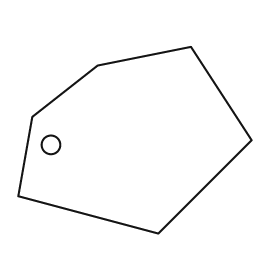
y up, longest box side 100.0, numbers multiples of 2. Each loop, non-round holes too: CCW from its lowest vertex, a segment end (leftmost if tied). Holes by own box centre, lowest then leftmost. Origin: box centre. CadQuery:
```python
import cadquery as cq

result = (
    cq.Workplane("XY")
    .moveTo(10.0, -40.0)
    .lineTo(50.0, 0.0)
    .lineTo(24.0, 40.0)
    .lineTo(-16.0, 32.0)
    .lineTo(-44.0, 10.0)
    .lineTo(-50.0, -24.0)
    .close()
    .moveTo(-36.0, -2.0)
    .circle(4.0)
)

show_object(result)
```